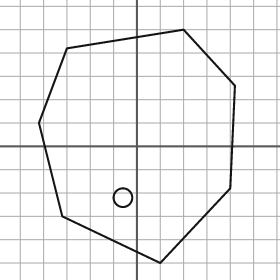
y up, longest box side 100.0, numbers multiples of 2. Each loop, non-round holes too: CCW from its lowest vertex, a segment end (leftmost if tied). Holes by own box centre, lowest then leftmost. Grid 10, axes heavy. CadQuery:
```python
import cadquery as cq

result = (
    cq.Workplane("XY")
    .moveTo(10.0, -50.0)
    .lineTo(40.0, -18.0)
    .lineTo(42.0, 26.0)
    .lineTo(20.0, 50.0)
    .lineTo(-30.0, 42.0)
    .lineTo(-42.0, 10.0)
    .lineTo(-32.0, -30.0)
    .close()
    .moveTo(-6.0, -22.0)
    .circle(4.0)
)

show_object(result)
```